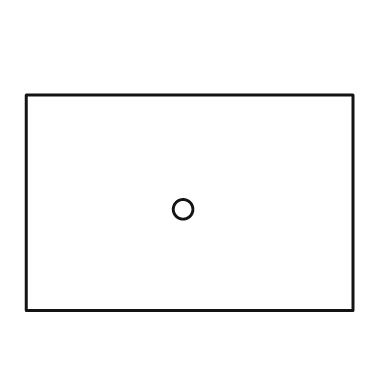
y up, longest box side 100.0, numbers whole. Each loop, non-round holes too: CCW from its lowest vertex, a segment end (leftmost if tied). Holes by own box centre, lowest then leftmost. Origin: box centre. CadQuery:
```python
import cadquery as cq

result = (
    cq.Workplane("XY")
    .moveTo(-50.0, -33.0)
    .lineTo(50.0, -33.0)
    .lineTo(50.0, 33.0)
    .lineTo(-50.0, 33.0)
    .close()
    .moveTo(-2.0, -2.0)
    .circle(3.0)
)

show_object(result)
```